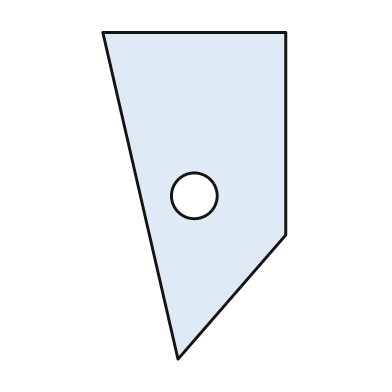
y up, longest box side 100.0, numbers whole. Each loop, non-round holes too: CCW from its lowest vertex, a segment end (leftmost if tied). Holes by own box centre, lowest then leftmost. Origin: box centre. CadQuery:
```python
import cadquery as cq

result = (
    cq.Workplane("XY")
    .moveTo(-5.0, -50.0)
    .lineTo(28.0, -12.0)
    .lineTo(28.0, 50.0)
    .lineTo(-28.0, 50.0)
    .close()
    .moveTo(0.0, 0.0)
    .circle(7.0)
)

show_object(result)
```